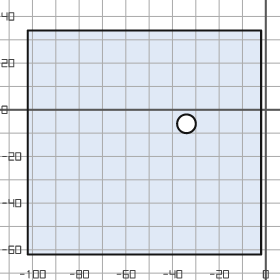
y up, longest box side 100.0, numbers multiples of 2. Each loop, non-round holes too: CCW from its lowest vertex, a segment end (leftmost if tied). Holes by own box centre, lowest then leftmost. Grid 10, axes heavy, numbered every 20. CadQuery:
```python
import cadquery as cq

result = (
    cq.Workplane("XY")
    .moveTo(-102.0, -62.0)
    .lineTo(-2.0, -62.0)
    .lineTo(-2.0, 34.0)
    .lineTo(-102.0, 34.0)
    .close()
    .moveTo(-34.0, -6.0)
    .circle(4.0)
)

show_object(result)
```